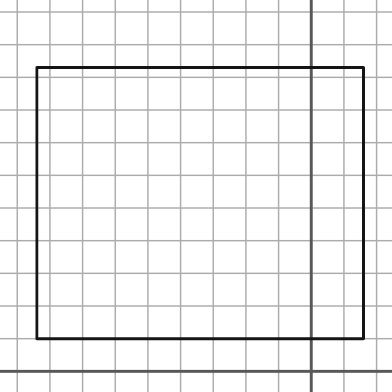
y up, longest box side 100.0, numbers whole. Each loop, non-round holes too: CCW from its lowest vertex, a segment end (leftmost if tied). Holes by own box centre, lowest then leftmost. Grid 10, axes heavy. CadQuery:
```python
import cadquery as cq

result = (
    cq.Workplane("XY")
    .moveTo(-84.0, 10.0)
    .lineTo(16.0, 10.0)
    .lineTo(16.0, 93.0)
    .lineTo(-84.0, 93.0)
    .close()
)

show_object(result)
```